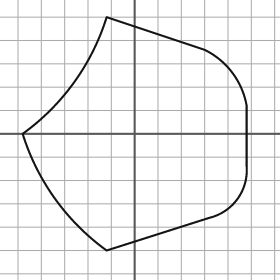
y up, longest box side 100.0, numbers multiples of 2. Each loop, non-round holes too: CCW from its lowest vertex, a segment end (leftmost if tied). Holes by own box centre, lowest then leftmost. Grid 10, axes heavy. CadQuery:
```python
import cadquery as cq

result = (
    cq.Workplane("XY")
    .moveTo(-12.0, -50.0)
    .lineTo(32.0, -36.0)
    .threePointArc((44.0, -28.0), (48.0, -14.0))
    .lineTo(48.0, 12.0)
    .threePointArc((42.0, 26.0), (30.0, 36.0))
    .lineTo(-12.0, 50.0)
    .threePointArc((-26.0, 22.0), (-48.0, 0.0))
    .threePointArc((-34.0, -28.0), (-12.0, -50.0))
    .close()
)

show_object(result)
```